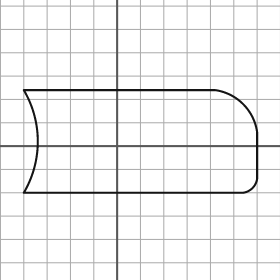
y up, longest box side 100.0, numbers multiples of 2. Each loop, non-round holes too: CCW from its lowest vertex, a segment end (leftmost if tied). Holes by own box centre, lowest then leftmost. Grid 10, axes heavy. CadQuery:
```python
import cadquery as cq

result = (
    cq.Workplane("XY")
    .moveTo(-40.0, -20.0)
    .lineTo(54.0, -20.0)
    .threePointArc((58.0, -18.0), (60.0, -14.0))
    .lineTo(60.0, 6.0)
    .threePointArc((54.0, 18.0), (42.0, 24.0))
    .lineTo(-40.0, 24.0)
    .threePointArc((-34.0, 2.0), (-40.0, -20.0))
    .close()
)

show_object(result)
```